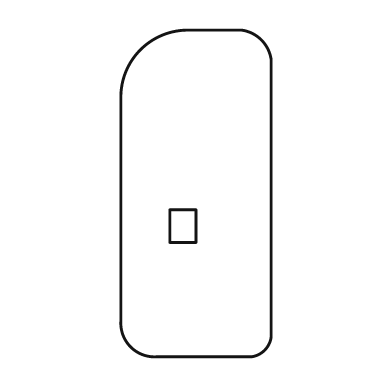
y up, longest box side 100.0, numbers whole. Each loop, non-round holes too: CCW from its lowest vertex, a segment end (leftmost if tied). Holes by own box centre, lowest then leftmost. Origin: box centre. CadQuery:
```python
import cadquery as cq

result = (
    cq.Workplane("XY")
    .moveTo(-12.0, -50.0)
    .lineTo(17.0, -50.0)
    .threePointArc((21.0, -48.0), (23.0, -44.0))
    .lineTo(23.0, 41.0)
    .threePointArc((20.0, 47.0), (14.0, 50.0))
    .lineTo(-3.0, 50.0)
    .threePointArc((-17.0, 44.0), (-23.0, 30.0))
    .lineTo(-23.0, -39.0)
    .threePointArc((-20.0, -47.0), (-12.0, -50.0))
    .close()
    .moveTo(-8.0, -15.0)
    .lineTo(0.0, -15.0)
    .lineTo(0.0, -5.0)
    .lineTo(-8.0, -5.0)
    .close()
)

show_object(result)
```